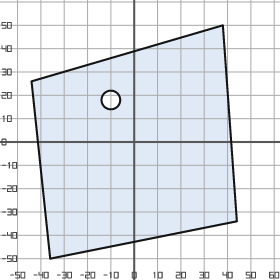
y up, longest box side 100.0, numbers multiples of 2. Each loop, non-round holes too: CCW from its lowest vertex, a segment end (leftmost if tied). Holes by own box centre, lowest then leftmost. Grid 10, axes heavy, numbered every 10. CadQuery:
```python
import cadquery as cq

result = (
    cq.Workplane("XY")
    .moveTo(-36.0, -50.0)
    .lineTo(44.0, -34.0)
    .lineTo(38.0, 50.0)
    .lineTo(-44.0, 26.0)
    .close()
    .moveTo(-10.0, 18.0)
    .circle(4.0)
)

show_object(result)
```